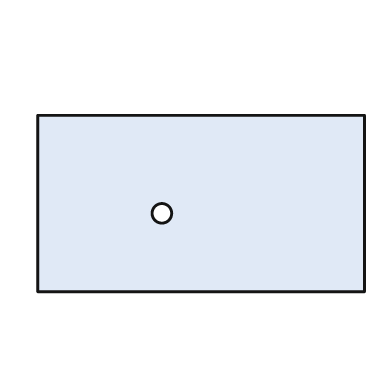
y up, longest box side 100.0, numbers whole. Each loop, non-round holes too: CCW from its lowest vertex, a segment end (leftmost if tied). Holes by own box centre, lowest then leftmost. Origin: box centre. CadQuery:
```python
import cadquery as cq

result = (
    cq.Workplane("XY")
    .moveTo(-50.0, -27.0)
    .lineTo(50.0, -27.0)
    .lineTo(50.0, 27.0)
    .lineTo(-50.0, 27.0)
    .close()
    .moveTo(-12.0, -3.0)
    .circle(3.0)
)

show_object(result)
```